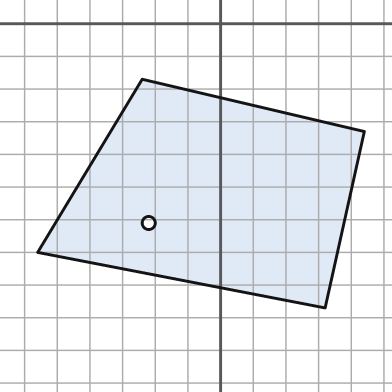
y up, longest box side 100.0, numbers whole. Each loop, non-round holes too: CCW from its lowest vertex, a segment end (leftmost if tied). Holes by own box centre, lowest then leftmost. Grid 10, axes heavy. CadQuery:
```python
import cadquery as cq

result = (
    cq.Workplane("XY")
    .moveTo(32.0, -87.0)
    .lineTo(44.0, -33.0)
    .lineTo(-24.0, -17.0)
    .lineTo(-56.0, -70.0)
    .close()
    .moveTo(-22.0, -61.0)
    .circle(2.0)
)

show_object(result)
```